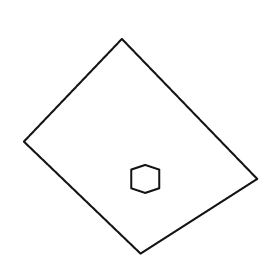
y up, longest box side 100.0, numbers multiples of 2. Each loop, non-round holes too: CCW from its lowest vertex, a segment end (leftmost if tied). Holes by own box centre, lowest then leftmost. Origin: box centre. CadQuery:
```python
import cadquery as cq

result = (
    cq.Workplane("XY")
    .moveTo(0.0, -46.0)
    .lineTo(50.0, -14.0)
    .lineTo(-8.0, 46.0)
    .lineTo(-50.0, 2.0)
    .close()
    .moveTo(2.0, -20.0)
    .lineTo(8.0, -18.0)
    .lineTo(8.0, -10.0)
    .lineTo(2.0, -8.0)
    .lineTo(-4.0, -10.0)
    .lineTo(-4.0, -18.0)
    .close()
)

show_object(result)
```